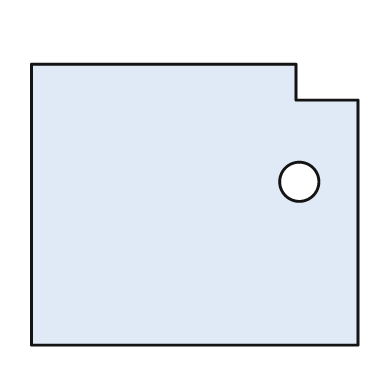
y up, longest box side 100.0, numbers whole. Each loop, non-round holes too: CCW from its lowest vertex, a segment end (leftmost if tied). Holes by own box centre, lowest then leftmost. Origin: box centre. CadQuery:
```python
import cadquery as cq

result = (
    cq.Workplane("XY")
    .moveTo(-50.0, -43.0)
    .lineTo(50.0, -43.0)
    .lineTo(50.0, 32.0)
    .lineTo(31.0, 32.0)
    .lineTo(31.0, 43.0)
    .lineTo(-50.0, 43.0)
    .close()
    .moveTo(32.0, 7.0)
    .circle(6.0)
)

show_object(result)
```